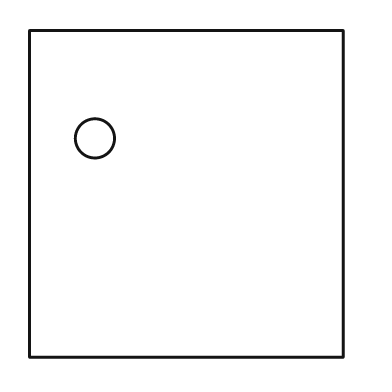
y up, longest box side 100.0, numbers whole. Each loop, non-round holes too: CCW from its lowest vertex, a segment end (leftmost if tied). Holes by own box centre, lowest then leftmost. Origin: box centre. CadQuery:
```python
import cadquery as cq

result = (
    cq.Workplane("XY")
    .moveTo(-48.0, -50.0)
    .lineTo(48.0, -50.0)
    .lineTo(48.0, 50.0)
    .lineTo(-48.0, 50.0)
    .close()
    .moveTo(-28.0, 17.0)
    .circle(6.0)
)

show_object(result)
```